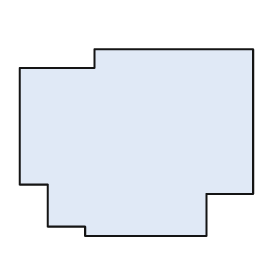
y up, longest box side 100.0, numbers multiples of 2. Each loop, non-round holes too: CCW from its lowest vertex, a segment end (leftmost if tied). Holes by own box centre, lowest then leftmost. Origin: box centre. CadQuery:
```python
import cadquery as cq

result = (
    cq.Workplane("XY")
    .moveTo(-22.0, -40.0)
    .lineTo(30.0, -40.0)
    .lineTo(30.0, -22.0)
    .lineTo(50.0, -22.0)
    .lineTo(50.0, 40.0)
    .lineTo(-18.0, 40.0)
    .lineTo(-18.0, 32.0)
    .lineTo(-50.0, 32.0)
    .lineTo(-50.0, -18.0)
    .lineTo(-38.0, -18.0)
    .lineTo(-38.0, -36.0)
    .lineTo(-22.0, -36.0)
    .close()
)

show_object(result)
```